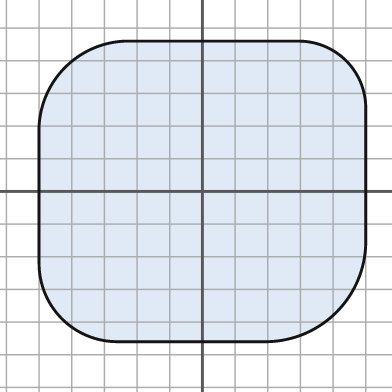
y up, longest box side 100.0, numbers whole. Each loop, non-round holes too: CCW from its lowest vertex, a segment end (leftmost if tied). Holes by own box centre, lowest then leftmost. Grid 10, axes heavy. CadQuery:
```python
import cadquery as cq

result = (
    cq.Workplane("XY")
    .moveTo(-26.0, -46.0)
    .lineTo(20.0, -46.0)
    .threePointArc((41.0, -37.0), (50.0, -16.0))
    .lineTo(50.0, 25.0)
    .threePointArc((44.0, 40.0), (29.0, 46.0))
    .lineTo(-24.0, 46.0)
    .threePointArc((-42.0, 38.0), (-50.0, 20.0))
    .lineTo(-50.0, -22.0)
    .threePointArc((-43.0, -39.0), (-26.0, -46.0))
    .close()
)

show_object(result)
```